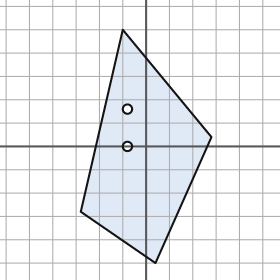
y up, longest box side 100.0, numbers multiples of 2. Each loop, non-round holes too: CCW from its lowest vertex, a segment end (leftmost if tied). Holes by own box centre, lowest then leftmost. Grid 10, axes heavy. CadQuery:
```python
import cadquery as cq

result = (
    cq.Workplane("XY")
    .moveTo(4.0, -50.0)
    .lineTo(28.0, 4.0)
    .lineTo(-10.0, 50.0)
    .lineTo(-28.0, -28.0)
    .close()
    .moveTo(-8.0, 0.0)
    .circle(2.0)
    .moveTo(-8.0, 16.0)
    .circle(2.0)
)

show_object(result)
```